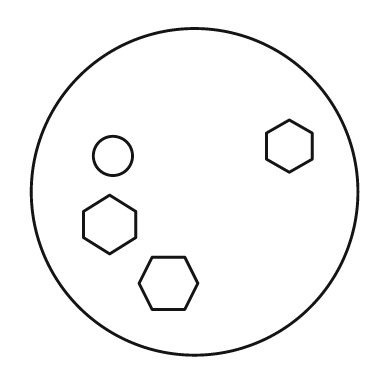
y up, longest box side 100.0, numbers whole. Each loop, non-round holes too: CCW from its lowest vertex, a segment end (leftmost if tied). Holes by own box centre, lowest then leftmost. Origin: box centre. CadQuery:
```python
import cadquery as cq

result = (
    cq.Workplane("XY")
    .moveTo(0.0, 0.0)
    .circle(50.0)
    .moveTo(-13.0, -36.0)
    .lineTo(-3.0, -36.0)
    .lineTo(1.0, -28.0)
    .lineTo(-3.0, -20.0)
    .lineTo(-13.0, -20.0)
    .lineTo(-17.0, -28.0)
    .close()
    .moveTo(-26.0, -19.0)
    .lineTo(-18.0, -14.0)
    .lineTo(-18.0, -6.0)
    .lineTo(-26.0, -1.0)
    .lineTo(-34.0, -6.0)
    .lineTo(-34.0, -14.0)
    .close()
    .moveTo(-25.0, 11.0)
    .circle(6.0)
    .moveTo(29.0, 6.0)
    .lineTo(36.0, 10.0)
    .lineTo(36.0, 18.0)
    .lineTo(29.0, 22.0)
    .lineTo(22.0, 18.0)
    .lineTo(22.0, 10.0)
    .close()
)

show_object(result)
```